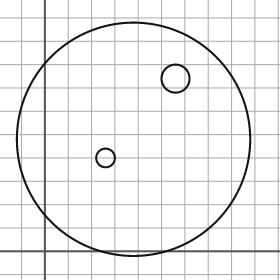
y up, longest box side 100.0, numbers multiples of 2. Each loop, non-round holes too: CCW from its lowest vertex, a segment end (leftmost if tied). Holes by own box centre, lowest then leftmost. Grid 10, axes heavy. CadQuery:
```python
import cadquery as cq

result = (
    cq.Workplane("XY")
    .moveTo(38.0, 48.0)
    .circle(50.0)
    .moveTo(26.0, 40.0)
    .circle(4.0)
    .moveTo(56.0, 74.0)
    .circle(6.0)
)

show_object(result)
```